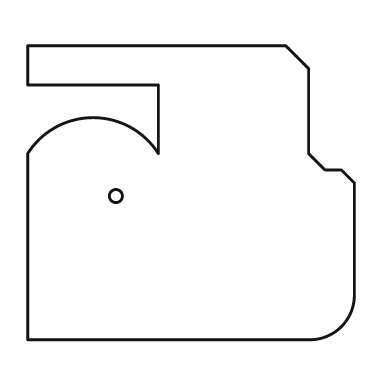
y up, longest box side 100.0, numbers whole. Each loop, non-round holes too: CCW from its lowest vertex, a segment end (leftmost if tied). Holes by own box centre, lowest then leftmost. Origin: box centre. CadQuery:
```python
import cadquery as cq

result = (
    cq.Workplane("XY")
    .moveTo(-50.0, -45.0)
    .lineTo(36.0, -45.0)
    .threePointArc((46.0, -41.0), (50.0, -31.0))
    .lineTo(50.0, 3.0)
    .lineTo(46.0, 7.0)
    .lineTo(41.0, 7.0)
    .lineTo(36.0, 12.0)
    .lineTo(36.0, 38.0)
    .lineTo(29.0, 45.0)
    .lineTo(-50.0, 45.0)
    .lineTo(-50.0, 33.0)
    .lineTo(-10.0, 33.0)
    .lineTo(-10.0, 12.0)
    .threePointArc((-30.0, 23.0), (-50.0, 12.0))
    .close()
    .moveTo(-23.0, -1.0)
    .circle(2.0)
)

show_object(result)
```